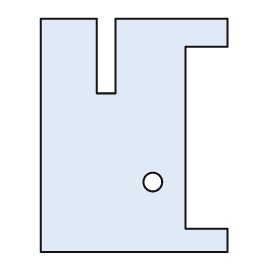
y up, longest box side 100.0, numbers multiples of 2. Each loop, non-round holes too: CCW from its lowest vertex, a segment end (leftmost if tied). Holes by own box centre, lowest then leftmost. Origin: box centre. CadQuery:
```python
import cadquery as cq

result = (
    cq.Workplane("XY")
    .moveTo(-40.0, -50.0)
    .lineTo(40.0, -50.0)
    .lineTo(40.0, -40.0)
    .lineTo(22.0, -40.0)
    .lineTo(22.0, 38.0)
    .lineTo(40.0, 38.0)
    .lineTo(40.0, 50.0)
    .lineTo(-8.0, 50.0)
    .lineTo(-8.0, 18.0)
    .lineTo(-16.0, 18.0)
    .lineTo(-16.0, 50.0)
    .lineTo(-40.0, 50.0)
    .close()
    .moveTo(8.0, -20.0)
    .circle(4.0)
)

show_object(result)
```